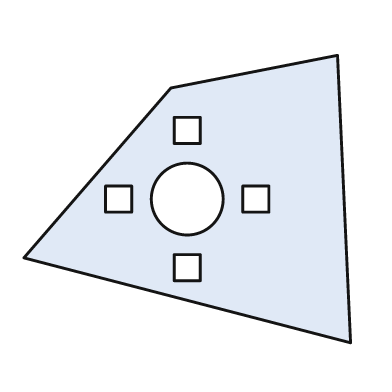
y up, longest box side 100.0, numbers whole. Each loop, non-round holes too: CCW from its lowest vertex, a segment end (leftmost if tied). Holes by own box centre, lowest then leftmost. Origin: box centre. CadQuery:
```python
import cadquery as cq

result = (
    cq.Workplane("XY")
    .moveTo(50.0, -44.0)
    .lineTo(46.0, 44.0)
    .lineTo(-5.0, 34.0)
    .lineTo(-50.0, -18.0)
    .close()
    .moveTo(-4.0, -25.0)
    .lineTo(4.0, -25.0)
    .lineTo(4.0, -17.0)
    .lineTo(-4.0, -17.0)
    .close()
    .moveTo(-25.0, -4.0)
    .lineTo(-17.0, -4.0)
    .lineTo(-17.0, 4.0)
    .lineTo(-25.0, 4.0)
    .close()
    .moveTo(0.0, 0.0)
    .circle(11.0)
    .moveTo(17.0, -4.0)
    .lineTo(25.0, -4.0)
    .lineTo(25.0, 4.0)
    .lineTo(17.0, 4.0)
    .close()
    .moveTo(-4.0, 17.0)
    .lineTo(4.0, 17.0)
    .lineTo(4.0, 25.0)
    .lineTo(-4.0, 25.0)
    .close()
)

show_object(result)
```